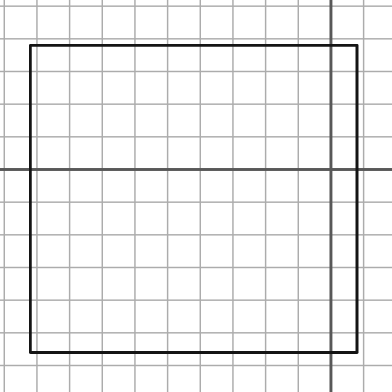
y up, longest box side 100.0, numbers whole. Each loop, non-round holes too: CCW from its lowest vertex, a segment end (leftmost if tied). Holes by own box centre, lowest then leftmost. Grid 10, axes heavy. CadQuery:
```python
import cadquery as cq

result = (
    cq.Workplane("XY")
    .moveTo(-92.0, -56.0)
    .lineTo(8.0, -56.0)
    .lineTo(8.0, 38.0)
    .lineTo(-92.0, 38.0)
    .close()
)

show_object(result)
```